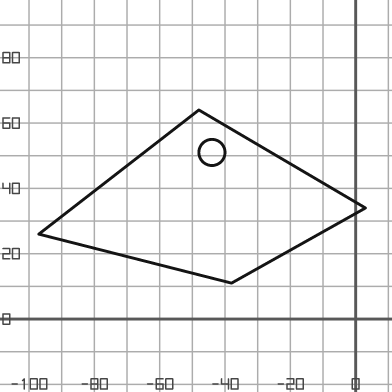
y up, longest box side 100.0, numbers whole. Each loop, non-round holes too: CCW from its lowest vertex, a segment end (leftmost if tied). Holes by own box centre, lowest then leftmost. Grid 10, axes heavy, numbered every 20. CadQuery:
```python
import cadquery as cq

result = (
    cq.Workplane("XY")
    .moveTo(-38.0, 11.0)
    .lineTo(3.0, 34.0)
    .lineTo(-48.0, 64.0)
    .lineTo(-97.0, 26.0)
    .close()
    .moveTo(-44.0, 51.0)
    .circle(4.0)
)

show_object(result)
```